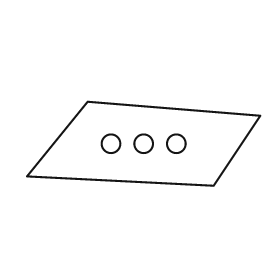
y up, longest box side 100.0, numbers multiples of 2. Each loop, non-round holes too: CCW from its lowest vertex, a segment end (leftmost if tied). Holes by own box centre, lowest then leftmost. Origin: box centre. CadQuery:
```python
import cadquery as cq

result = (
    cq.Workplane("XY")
    .moveTo(30.0, -18.0)
    .lineTo(50.0, 12.0)
    .lineTo(-24.0, 18.0)
    .lineTo(-50.0, -14.0)
    .close()
    .moveTo(-14.0, 0.0)
    .circle(4.0)
    .moveTo(0.0, 0.0)
    .circle(4.0)
    .moveTo(14.0, 0.0)
    .circle(4.0)
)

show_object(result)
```